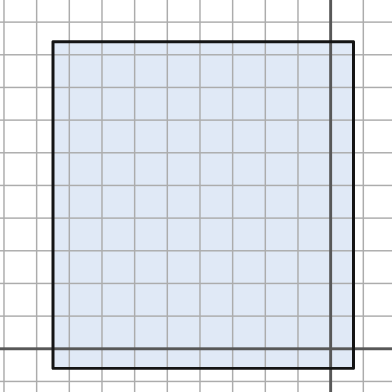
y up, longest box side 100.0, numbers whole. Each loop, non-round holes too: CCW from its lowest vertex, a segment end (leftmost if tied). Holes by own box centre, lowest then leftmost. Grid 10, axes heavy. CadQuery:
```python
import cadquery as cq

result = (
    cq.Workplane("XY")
    .moveTo(-85.0, -6.0)
    .lineTo(7.0, -6.0)
    .lineTo(7.0, 94.0)
    .lineTo(-85.0, 94.0)
    .close()
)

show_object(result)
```